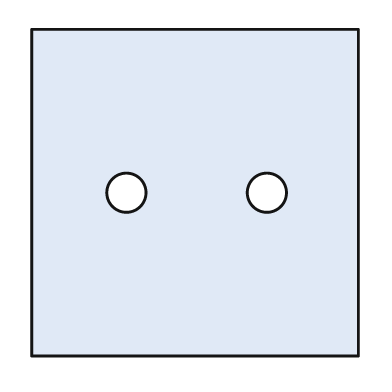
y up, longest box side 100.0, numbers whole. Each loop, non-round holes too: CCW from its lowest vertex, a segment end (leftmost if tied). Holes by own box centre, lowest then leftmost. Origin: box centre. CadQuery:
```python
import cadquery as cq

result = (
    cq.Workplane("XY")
    .moveTo(-50.0, -50.0)
    .lineTo(50.0, -50.0)
    .lineTo(50.0, 50.0)
    .lineTo(-50.0, 50.0)
    .close()
    .moveTo(-21.0, 0.0)
    .circle(6.0)
    .moveTo(22.0, 0.0)
    .circle(6.0)
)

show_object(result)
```